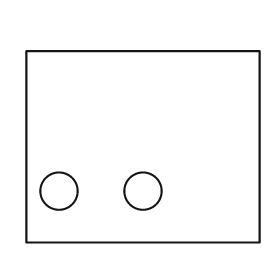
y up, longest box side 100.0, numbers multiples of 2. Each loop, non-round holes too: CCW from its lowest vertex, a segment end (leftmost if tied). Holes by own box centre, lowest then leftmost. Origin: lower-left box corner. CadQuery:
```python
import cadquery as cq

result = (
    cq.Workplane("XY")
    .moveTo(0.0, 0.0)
    .lineTo(100.0, 0.0)
    .lineTo(100.0, 82.0)
    .lineTo(0.0, 82.0)
    .close()
    .moveTo(14.0, 22.0)
    .circle(8.0)
    .moveTo(50.0, 22.0)
    .circle(8.0)
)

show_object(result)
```